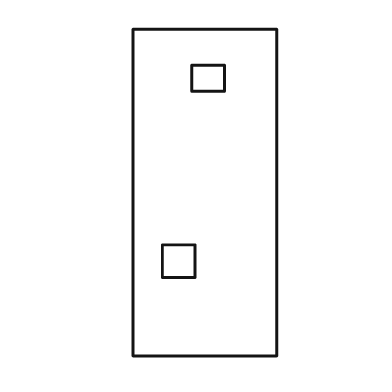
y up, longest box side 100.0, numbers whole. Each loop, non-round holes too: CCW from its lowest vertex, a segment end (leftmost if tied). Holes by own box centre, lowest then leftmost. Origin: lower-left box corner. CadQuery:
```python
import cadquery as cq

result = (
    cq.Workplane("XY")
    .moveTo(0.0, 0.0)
    .lineTo(44.0, 0.0)
    .lineTo(44.0, 100.0)
    .lineTo(0.0, 100.0)
    .close()
    .moveTo(9.0, 24.0)
    .lineTo(19.0, 24.0)
    .lineTo(19.0, 34.0)
    .lineTo(9.0, 34.0)
    .close()
    .moveTo(18.0, 81.0)
    .lineTo(28.0, 81.0)
    .lineTo(28.0, 89.0)
    .lineTo(18.0, 89.0)
    .close()
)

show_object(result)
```